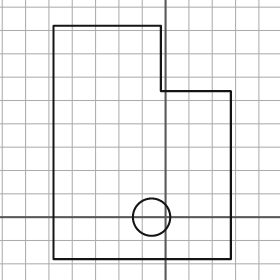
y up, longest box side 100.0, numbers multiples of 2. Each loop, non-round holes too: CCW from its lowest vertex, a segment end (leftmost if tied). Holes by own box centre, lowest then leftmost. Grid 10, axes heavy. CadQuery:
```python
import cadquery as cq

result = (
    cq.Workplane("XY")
    .moveTo(-48.0, -18.0)
    .lineTo(28.0, -18.0)
    .lineTo(28.0, 54.0)
    .lineTo(-2.0, 54.0)
    .lineTo(-2.0, 82.0)
    .lineTo(-48.0, 82.0)
    .close()
    .moveTo(-6.0, 0.0)
    .circle(8.0)
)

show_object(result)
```